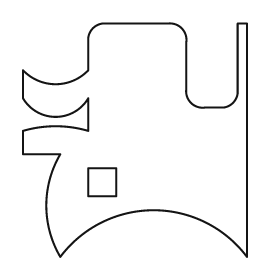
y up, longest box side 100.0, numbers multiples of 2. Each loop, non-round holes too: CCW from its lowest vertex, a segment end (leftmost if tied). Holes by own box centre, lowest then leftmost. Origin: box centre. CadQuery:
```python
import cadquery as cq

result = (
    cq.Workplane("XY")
    .moveTo(-32.0, -50.0)
    .threePointArc((8.0, -30.0), (48.0, -50.0))
    .lineTo(48.0, 50.0)
    .lineTo(44.0, 50.0)
    .lineTo(44.0, 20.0)
    .threePointArc((42.0, 16.0), (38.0, 14.0))
    .lineTo(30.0, 14.0)
    .threePointArc((24.0, 16.0), (22.0, 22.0))
    .lineTo(22.0, 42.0)
    .threePointArc((20.0, 48.0), (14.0, 50.0))
    .lineTo(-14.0, 50.0)
    .threePointArc((-18.0, 48.0), (-20.0, 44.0))
    .lineTo(-20.0, 30.0)
    .threePointArc((-34.0, 24.0), (-48.0, 30.0))
    .lineTo(-48.0, 18.0)
    .threePointArc((-34.0, 10.0), (-20.0, 18.0))
    .lineTo(-20.0, 4.0)
    .threePointArc((-34.0, 6.0), (-48.0, 4.0))
    .lineTo(-48.0, -6.0)
    .lineTo(-32.0, -6.0)
    .threePointArc((-38.0, -28.0), (-32.0, -50.0))
    .close()
    .moveTo(-20.0, -24.0)
    .lineTo(-8.0, -24.0)
    .lineTo(-8.0, -12.0)
    .lineTo(-20.0, -12.0)
    .close()
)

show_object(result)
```